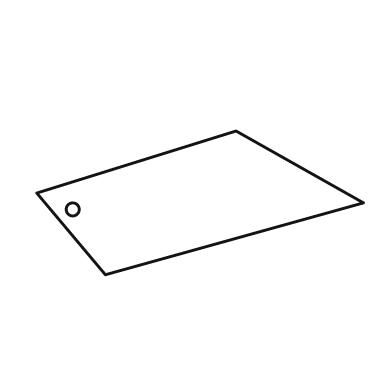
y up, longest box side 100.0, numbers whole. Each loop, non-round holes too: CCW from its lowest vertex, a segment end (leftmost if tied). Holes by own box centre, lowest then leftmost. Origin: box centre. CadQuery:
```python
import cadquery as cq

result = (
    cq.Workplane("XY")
    .moveTo(-29.0, -22.0)
    .lineTo(50.0, 0.0)
    .lineTo(11.0, 22.0)
    .lineTo(-50.0, 3.0)
    .close()
    .moveTo(-39.0, -2.0)
    .circle(2.0)
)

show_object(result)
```